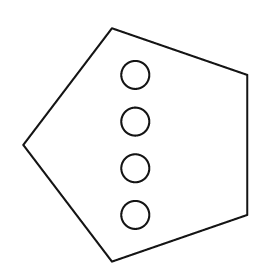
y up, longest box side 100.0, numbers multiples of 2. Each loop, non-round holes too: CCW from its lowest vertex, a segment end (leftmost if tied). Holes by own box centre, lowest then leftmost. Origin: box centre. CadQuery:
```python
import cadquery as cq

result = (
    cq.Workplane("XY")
    .moveTo(-10.0, -50.0)
    .lineTo(48.0, -30.0)
    .lineTo(48.0, 30.0)
    .lineTo(-10.0, 50.0)
    .lineTo(-48.0, 0.0)
    .close()
    .moveTo(0.0, -30.0)
    .circle(6.0)
    .moveTo(0.0, -10.0)
    .circle(6.0)
    .moveTo(0.0, 10.0)
    .circle(6.0)
    .moveTo(0.0, 30.0)
    .circle(6.0)
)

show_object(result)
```